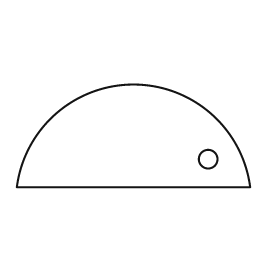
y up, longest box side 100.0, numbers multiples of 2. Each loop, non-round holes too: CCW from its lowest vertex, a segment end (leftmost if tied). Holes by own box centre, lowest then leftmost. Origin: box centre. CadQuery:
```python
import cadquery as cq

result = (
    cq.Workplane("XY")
    .moveTo(-50.0, -22.0)
    .lineTo(50.0, -22.0)
    .threePointArc((0.0, 22.0), (-50.0, -22.0))
    .close()
    .moveTo(32.0, -10.0)
    .circle(4.0)
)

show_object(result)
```